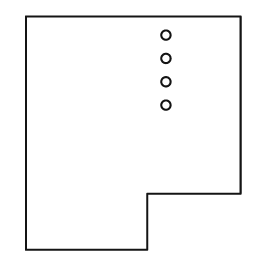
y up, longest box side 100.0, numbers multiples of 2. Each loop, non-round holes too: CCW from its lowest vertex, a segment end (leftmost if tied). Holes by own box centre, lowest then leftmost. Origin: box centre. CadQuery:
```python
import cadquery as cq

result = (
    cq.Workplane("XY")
    .moveTo(-46.0, -50.0)
    .lineTo(6.0, -50.0)
    .lineTo(6.0, -26.0)
    .lineTo(46.0, -26.0)
    .lineTo(46.0, 50.0)
    .lineTo(-46.0, 50.0)
    .close()
    .moveTo(14.0, 12.0)
    .circle(2.0)
    .moveTo(14.0, 22.0)
    .circle(2.0)
    .moveTo(14.0, 32.0)
    .circle(2.0)
    .moveTo(14.0, 42.0)
    .circle(2.0)
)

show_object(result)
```